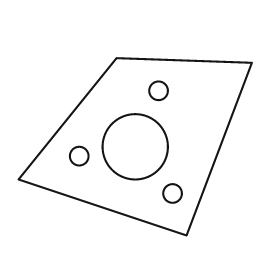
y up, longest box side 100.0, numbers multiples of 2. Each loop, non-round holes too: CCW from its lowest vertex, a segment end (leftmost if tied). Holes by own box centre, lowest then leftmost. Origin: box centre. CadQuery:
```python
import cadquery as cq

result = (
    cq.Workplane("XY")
    .moveTo(22.0, -38.0)
    .lineTo(50.0, 36.0)
    .lineTo(-8.0, 38.0)
    .lineTo(-50.0, -14.0)
    .close()
    .moveTo(16.0, -20.0)
    .circle(4.0)
    .moveTo(-24.0, -4.0)
    .circle(4.0)
    .moveTo(0.0, 0.0)
    .circle(14.0)
    .moveTo(10.0, 24.0)
    .circle(4.0)
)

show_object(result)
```